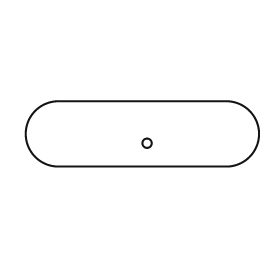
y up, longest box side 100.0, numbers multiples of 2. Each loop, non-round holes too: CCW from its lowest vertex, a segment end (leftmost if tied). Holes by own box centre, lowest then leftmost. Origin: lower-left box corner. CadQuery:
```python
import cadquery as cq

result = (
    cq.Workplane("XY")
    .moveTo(14.0, 0.0)
    .lineTo(86.0, 0.0)
    .threePointArc((100.0, 14.0), (86.0, 28.0))
    .lineTo(14.0, 28.0)
    .threePointArc((0.0, 14.0), (14.0, 0.0))
    .close()
    .moveTo(52.0, 10.0)
    .circle(2.0)
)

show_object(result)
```